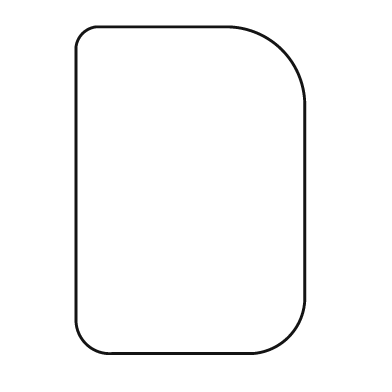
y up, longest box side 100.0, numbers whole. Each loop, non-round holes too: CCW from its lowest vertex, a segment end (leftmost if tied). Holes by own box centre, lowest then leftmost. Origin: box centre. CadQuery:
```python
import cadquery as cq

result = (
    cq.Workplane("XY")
    .moveTo(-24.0, -50.0)
    .lineTo(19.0, -50.0)
    .threePointArc((30.0, -45.0), (35.0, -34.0))
    .lineTo(35.0, 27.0)
    .threePointArc((28.0, 43.0), (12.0, 50.0))
    .lineTo(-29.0, 50.0)
    .threePointArc((-33.0, 48.0), (-35.0, 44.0))
    .lineTo(-35.0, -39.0)
    .threePointArc((-32.0, -47.0), (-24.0, -50.0))
    .close()
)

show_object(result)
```